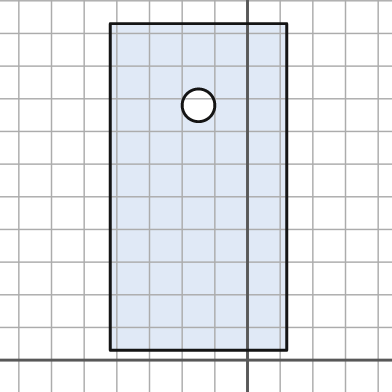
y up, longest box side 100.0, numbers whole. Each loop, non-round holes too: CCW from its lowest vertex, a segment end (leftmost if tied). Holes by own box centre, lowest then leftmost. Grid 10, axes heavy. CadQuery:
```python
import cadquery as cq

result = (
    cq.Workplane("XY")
    .moveTo(-42.0, 3.0)
    .lineTo(12.0, 3.0)
    .lineTo(12.0, 103.0)
    .lineTo(-42.0, 103.0)
    .close()
    .moveTo(-15.0, 78.0)
    .circle(5.0)
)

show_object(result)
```